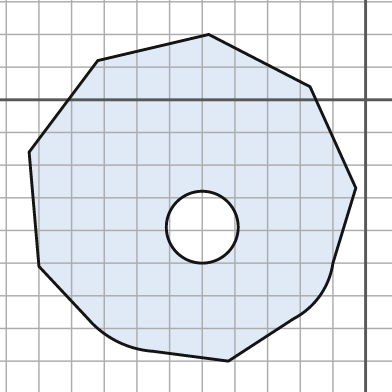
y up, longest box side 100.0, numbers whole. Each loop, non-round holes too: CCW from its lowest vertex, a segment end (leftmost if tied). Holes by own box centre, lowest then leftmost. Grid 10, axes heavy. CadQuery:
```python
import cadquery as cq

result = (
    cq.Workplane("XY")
    .moveTo(-42.0, -80.0)
    .lineTo(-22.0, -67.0)
    .threePointArc((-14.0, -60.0), (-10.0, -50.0))
    .lineTo(-3.0, -27.0)
    .lineTo(-17.0, 4.0)
    .lineTo(-48.0, 20.0)
    .lineTo(-82.0, 12.0)
    .lineTo(-103.0, -16.0)
    .lineTo(-100.0, -51.0)
    .lineTo(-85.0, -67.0)
    .threePointArc((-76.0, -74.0), (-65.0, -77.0))
    .close()
    .moveTo(-50.0, -39.0)
    .circle(11.0)
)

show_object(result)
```